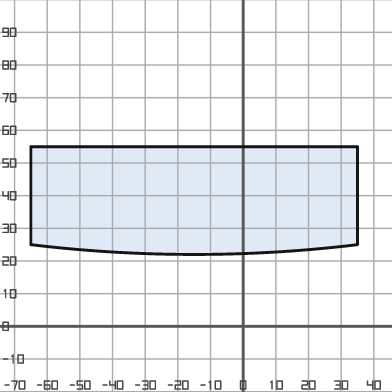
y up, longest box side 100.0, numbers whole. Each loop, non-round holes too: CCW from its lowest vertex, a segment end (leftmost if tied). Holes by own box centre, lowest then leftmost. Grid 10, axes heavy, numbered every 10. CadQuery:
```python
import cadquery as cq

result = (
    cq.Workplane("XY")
    .moveTo(-65.0, 25.0)
    .threePointArc((-15.0, 22.0), (35.0, 25.0))
    .lineTo(35.0, 55.0)
    .lineTo(-65.0, 55.0)
    .close()
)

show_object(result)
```